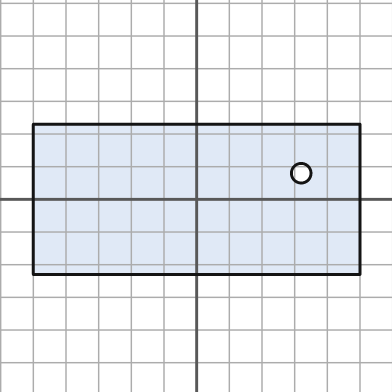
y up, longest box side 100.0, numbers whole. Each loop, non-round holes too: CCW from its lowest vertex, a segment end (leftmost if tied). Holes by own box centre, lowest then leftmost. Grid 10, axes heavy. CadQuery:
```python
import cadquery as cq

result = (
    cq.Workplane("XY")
    .moveTo(-50.0, -23.0)
    .lineTo(50.0, -23.0)
    .lineTo(50.0, 23.0)
    .lineTo(-50.0, 23.0)
    .close()
    .moveTo(32.0, 8.0)
    .circle(3.0)
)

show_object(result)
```